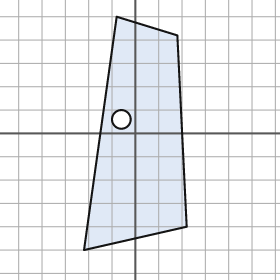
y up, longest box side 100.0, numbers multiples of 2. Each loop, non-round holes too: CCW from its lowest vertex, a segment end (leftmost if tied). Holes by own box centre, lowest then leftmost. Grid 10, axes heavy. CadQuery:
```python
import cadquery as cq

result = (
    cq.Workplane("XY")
    .moveTo(-22.0, -50.0)
    .lineTo(22.0, -40.0)
    .lineTo(18.0, 42.0)
    .lineTo(-8.0, 50.0)
    .close()
    .moveTo(-6.0, 6.0)
    .circle(4.0)
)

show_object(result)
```